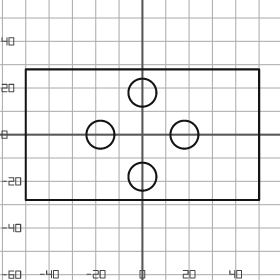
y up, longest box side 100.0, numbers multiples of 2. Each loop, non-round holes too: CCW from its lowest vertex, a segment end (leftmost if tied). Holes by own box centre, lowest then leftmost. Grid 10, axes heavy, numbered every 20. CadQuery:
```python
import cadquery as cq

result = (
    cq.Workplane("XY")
    .moveTo(-50.0, -28.0)
    .lineTo(50.0, -28.0)
    .lineTo(50.0, 28.0)
    .lineTo(-50.0, 28.0)
    .close()
    .moveTo(0.0, -18.0)
    .circle(6.0)
    .moveTo(-18.0, 0.0)
    .circle(6.0)
    .moveTo(18.0, 0.0)
    .circle(6.0)
    .moveTo(0.0, 18.0)
    .circle(6.0)
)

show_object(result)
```